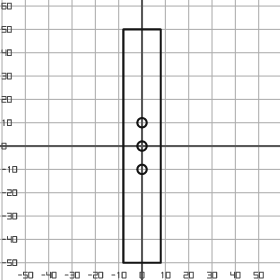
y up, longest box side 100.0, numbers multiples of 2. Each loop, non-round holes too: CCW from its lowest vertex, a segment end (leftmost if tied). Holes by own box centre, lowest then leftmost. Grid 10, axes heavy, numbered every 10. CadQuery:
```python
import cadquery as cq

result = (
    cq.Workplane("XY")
    .moveTo(-8.0, -50.0)
    .lineTo(8.0, -50.0)
    .lineTo(8.0, 50.0)
    .lineTo(-8.0, 50.0)
    .close()
    .moveTo(0.0, -10.0)
    .circle(2.0)
    .moveTo(0.0, 0.0)
    .circle(2.0)
    .moveTo(0.0, 10.0)
    .circle(2.0)
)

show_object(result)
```